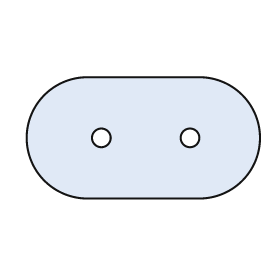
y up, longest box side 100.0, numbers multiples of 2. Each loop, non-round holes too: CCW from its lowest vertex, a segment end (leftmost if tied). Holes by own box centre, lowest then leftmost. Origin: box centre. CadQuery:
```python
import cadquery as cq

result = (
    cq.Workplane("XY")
    .moveTo(-24.0, -26.0)
    .lineTo(24.0, -26.0)
    .threePointArc((50.0, 0.0), (24.0, 26.0))
    .lineTo(-24.0, 26.0)
    .threePointArc((-50.0, 0.0), (-24.0, -26.0))
    .close()
    .moveTo(-18.0, 0.0)
    .circle(4.0)
    .moveTo(20.0, 0.0)
    .circle(4.0)
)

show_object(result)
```